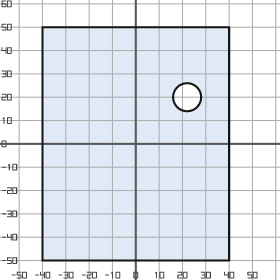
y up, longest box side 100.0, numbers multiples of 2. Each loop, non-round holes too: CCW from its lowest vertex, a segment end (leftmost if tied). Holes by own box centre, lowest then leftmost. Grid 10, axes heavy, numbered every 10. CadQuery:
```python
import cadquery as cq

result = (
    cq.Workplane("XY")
    .moveTo(-40.0, -50.0)
    .lineTo(40.0, -50.0)
    .lineTo(40.0, 50.0)
    .lineTo(-40.0, 50.0)
    .close()
    .moveTo(22.0, 20.0)
    .circle(6.0)
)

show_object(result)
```